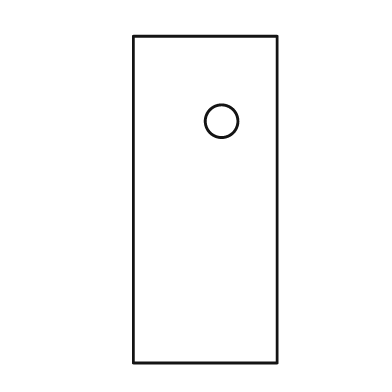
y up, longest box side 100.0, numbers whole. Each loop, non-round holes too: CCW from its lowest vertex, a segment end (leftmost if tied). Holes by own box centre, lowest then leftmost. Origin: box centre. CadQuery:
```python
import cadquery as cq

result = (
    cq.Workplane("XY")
    .moveTo(-22.0, -50.0)
    .lineTo(22.0, -50.0)
    .lineTo(22.0, 50.0)
    .lineTo(-22.0, 50.0)
    .close()
    .moveTo(5.0, 24.0)
    .circle(5.0)
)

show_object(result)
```